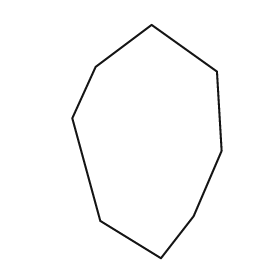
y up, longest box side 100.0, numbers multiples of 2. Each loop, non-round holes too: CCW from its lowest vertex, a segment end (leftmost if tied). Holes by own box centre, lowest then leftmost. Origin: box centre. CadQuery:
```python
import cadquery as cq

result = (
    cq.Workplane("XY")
    .moveTo(6.0, -50.0)
    .lineTo(20.0, -32.0)
    .lineTo(32.0, -4.0)
    .lineTo(30.0, 30.0)
    .lineTo(2.0, 50.0)
    .lineTo(-22.0, 32.0)
    .lineTo(-32.0, 10.0)
    .lineTo(-20.0, -34.0)
    .close()
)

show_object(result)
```